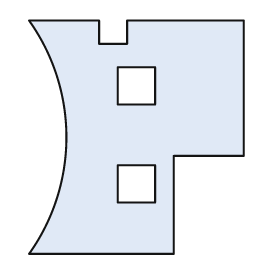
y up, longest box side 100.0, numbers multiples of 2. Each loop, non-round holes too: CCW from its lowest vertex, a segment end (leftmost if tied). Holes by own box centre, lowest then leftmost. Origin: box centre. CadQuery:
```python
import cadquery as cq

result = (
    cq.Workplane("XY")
    .moveTo(-46.0, -50.0)
    .lineTo(16.0, -50.0)
    .lineTo(16.0, -8.0)
    .lineTo(46.0, -8.0)
    .lineTo(46.0, 50.0)
    .lineTo(-4.0, 50.0)
    .lineTo(-4.0, 40.0)
    .lineTo(-16.0, 40.0)
    .lineTo(-16.0, 50.0)
    .lineTo(-46.0, 50.0)
    .threePointArc((-30.0, 0.0), (-46.0, -50.0))
    .close()
    .moveTo(-8.0, -28.0)
    .lineTo(8.0, -28.0)
    .lineTo(8.0, -12.0)
    .lineTo(-8.0, -12.0)
    .close()
    .moveTo(-8.0, 14.0)
    .lineTo(8.0, 14.0)
    .lineTo(8.0, 30.0)
    .lineTo(-8.0, 30.0)
    .close()
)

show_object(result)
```